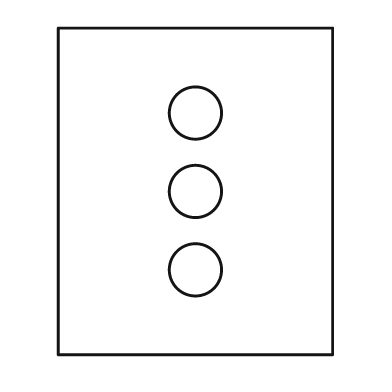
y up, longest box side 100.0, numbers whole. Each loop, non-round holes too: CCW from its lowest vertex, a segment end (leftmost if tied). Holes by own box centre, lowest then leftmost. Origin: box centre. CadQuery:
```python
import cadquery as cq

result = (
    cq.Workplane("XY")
    .moveTo(-42.0, -50.0)
    .lineTo(42.0, -50.0)
    .lineTo(42.0, 50.0)
    .lineTo(-42.0, 50.0)
    .close()
    .moveTo(0.0, -24.0)
    .circle(8.0)
    .moveTo(0.0, 0.0)
    .circle(8.0)
    .moveTo(0.0, 24.0)
    .circle(8.0)
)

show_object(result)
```